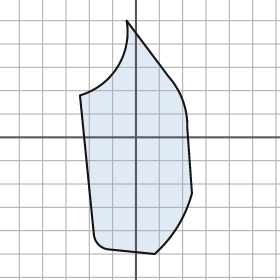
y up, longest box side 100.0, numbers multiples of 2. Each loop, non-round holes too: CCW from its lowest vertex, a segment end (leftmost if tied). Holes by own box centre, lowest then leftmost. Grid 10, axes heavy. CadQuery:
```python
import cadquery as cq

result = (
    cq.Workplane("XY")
    .moveTo(8.0, -50.0)
    .threePointArc((18.0, -38.0), (24.0, -24.0))
    .lineTo(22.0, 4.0)
    .threePointArc((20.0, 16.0), (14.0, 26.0))
    .lineTo(-4.0, 50.0)
    .threePointArc((-8.0, 30.0), (-24.0, 18.0))
    .lineTo(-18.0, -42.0)
    .threePointArc((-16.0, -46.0), (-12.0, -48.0))
    .close()
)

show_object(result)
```